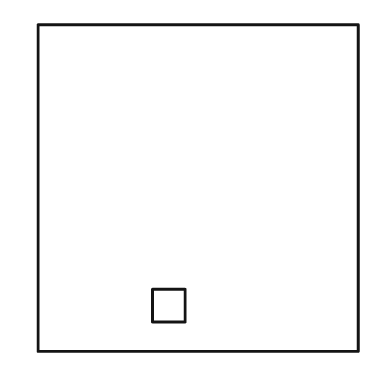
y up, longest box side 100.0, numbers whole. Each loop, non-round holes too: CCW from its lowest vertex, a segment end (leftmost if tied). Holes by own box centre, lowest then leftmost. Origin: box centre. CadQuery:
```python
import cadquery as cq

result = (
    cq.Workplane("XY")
    .moveTo(-49.0, -50.0)
    .lineTo(49.0, -50.0)
    .lineTo(49.0, 50.0)
    .lineTo(-49.0, 50.0)
    .close()
    .moveTo(-14.0, -41.0)
    .lineTo(-4.0, -41.0)
    .lineTo(-4.0, -31.0)
    .lineTo(-14.0, -31.0)
    .close()
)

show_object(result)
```